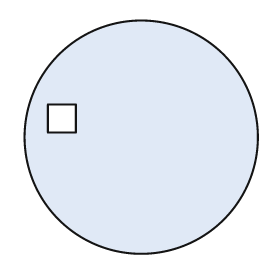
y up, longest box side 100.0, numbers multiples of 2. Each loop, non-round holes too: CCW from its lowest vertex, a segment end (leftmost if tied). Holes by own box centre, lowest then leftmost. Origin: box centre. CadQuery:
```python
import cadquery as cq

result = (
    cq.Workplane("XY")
    .moveTo(0.0, 0.0)
    .circle(50.0)
    .moveTo(-40.0, 2.0)
    .lineTo(-28.0, 2.0)
    .lineTo(-28.0, 14.0)
    .lineTo(-40.0, 14.0)
    .close()
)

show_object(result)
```